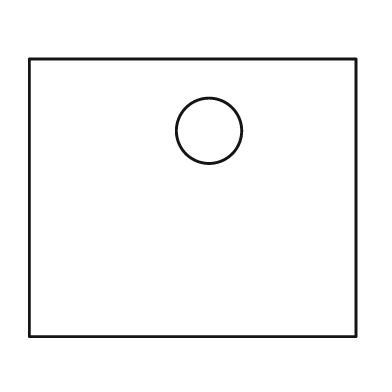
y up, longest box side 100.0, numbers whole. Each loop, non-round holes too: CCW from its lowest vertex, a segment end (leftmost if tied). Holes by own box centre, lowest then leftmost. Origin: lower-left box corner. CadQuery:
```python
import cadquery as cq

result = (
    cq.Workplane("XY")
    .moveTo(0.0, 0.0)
    .lineTo(100.0, 0.0)
    .lineTo(100.0, 85.0)
    .lineTo(0.0, 85.0)
    .close()
    .moveTo(55.0, 63.0)
    .circle(10.0)
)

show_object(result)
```